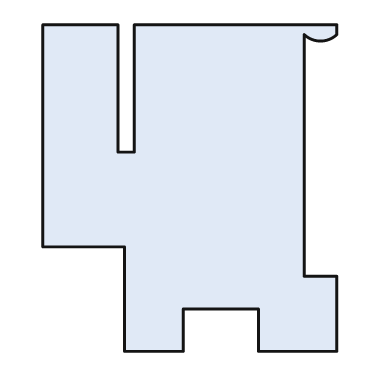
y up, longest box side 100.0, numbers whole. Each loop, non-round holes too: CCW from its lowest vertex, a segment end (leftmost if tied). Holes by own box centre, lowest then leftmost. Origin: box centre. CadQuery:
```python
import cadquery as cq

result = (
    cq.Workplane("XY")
    .moveTo(-20.0, -50.0)
    .lineTo(-2.0, -50.0)
    .lineTo(-2.0, -37.0)
    .lineTo(21.0, -37.0)
    .lineTo(21.0, -50.0)
    .lineTo(45.0, -50.0)
    .lineTo(45.0, -27.0)
    .lineTo(35.0, -27.0)
    .lineTo(35.0, 47.0)
    .threePointArc((40.0, 45.0), (45.0, 47.0))
    .lineTo(45.0, 50.0)
    .lineTo(-17.0, 50.0)
    .lineTo(-17.0, 11.0)
    .lineTo(-22.0, 11.0)
    .lineTo(-22.0, 50.0)
    .lineTo(-45.0, 50.0)
    .lineTo(-45.0, -18.0)
    .lineTo(-20.0, -18.0)
    .close()
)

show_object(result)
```